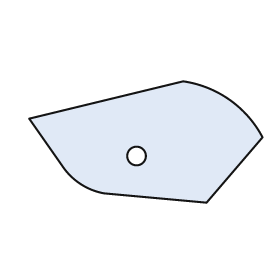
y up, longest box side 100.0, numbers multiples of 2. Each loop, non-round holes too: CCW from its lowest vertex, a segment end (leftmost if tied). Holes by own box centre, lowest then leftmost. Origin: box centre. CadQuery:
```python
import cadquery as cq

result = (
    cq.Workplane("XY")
    .moveTo(26.0, -26.0)
    .lineTo(50.0, 2.0)
    .threePointArc((36.0, 18.0), (16.0, 26.0))
    .lineTo(-50.0, 10.0)
    .lineTo(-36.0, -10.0)
    .threePointArc((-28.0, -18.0), (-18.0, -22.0))
    .close()
    .moveTo(-4.0, -6.0)
    .circle(4.0)
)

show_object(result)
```